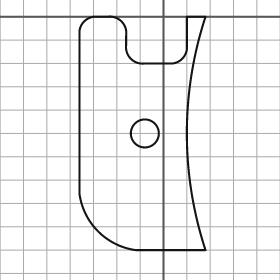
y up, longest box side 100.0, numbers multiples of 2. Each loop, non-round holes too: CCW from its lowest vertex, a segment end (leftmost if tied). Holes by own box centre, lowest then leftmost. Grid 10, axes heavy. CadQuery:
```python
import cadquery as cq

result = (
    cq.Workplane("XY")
    .moveTo(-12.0, -100.0)
    .lineTo(18.0, -100.0)
    .threePointArc((10.0, -50.0), (18.0, 0.0))
    .lineTo(10.0, 0.0)
    .lineTo(10.0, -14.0)
    .threePointArc((8.0, -18.0), (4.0, -20.0))
    .lineTo(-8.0, -20.0)
    .threePointArc((-14.0, -18.0), (-16.0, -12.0))
    .lineTo(-16.0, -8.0)
    .threePointArc((-18.0, -2.0), (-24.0, 0.0))
    .lineTo(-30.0, 0.0)
    .threePointArc((-34.0, -2.0), (-36.0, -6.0))
    .lineTo(-36.0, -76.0)
    .threePointArc((-28.0, -92.0), (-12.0, -100.0))
    .close()
    .moveTo(-8.0, -50.0)
    .circle(6.0)
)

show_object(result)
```